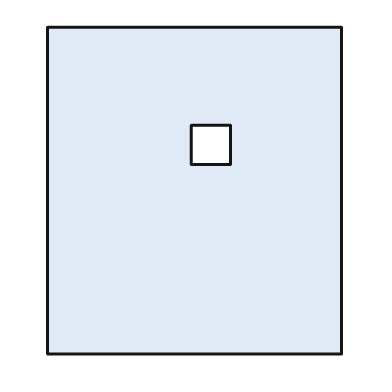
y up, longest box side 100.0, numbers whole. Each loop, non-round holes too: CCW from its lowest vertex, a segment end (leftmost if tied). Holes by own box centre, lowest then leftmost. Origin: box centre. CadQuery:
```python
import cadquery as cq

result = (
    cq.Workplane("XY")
    .moveTo(-45.0, -50.0)
    .lineTo(45.0, -50.0)
    .lineTo(45.0, 50.0)
    .lineTo(-45.0, 50.0)
    .close()
    .moveTo(-1.0, 8.0)
    .lineTo(11.0, 8.0)
    .lineTo(11.0, 20.0)
    .lineTo(-1.0, 20.0)
    .close()
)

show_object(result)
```